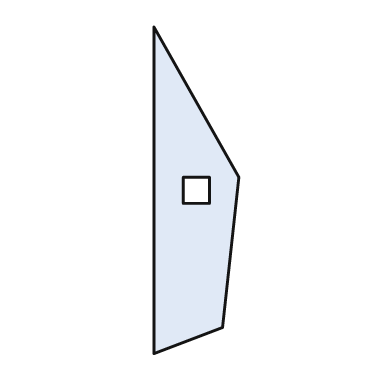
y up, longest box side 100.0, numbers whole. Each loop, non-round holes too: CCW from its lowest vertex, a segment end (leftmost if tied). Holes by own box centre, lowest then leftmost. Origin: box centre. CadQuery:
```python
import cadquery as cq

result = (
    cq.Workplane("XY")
    .moveTo(-13.0, -50.0)
    .lineTo(8.0, -42.0)
    .lineTo(13.0, 4.0)
    .lineTo(-13.0, 50.0)
    .close()
    .moveTo(-4.0, -4.0)
    .lineTo(4.0, -4.0)
    .lineTo(4.0, 4.0)
    .lineTo(-4.0, 4.0)
    .close()
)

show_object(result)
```